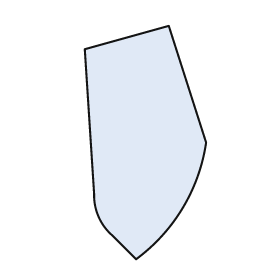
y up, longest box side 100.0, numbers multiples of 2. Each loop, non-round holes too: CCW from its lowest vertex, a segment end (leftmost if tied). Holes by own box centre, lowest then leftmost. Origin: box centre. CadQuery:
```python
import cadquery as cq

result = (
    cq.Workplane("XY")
    .moveTo(-4.0, -50.0)
    .threePointArc((16.0, -28.0), (26.0, 0.0))
    .lineTo(10.0, 50.0)
    .lineTo(-26.0, 40.0)
    .lineTo(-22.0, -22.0)
    .threePointArc((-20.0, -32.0), (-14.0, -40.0))
    .close()
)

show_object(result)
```